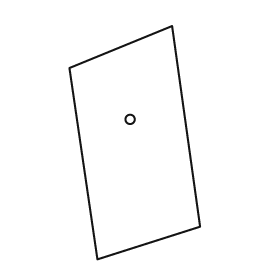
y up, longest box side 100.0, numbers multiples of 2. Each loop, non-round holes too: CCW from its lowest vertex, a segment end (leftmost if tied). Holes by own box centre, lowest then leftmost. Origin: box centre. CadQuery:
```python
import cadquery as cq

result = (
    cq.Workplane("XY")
    .moveTo(-16.0, -50.0)
    .lineTo(28.0, -36.0)
    .lineTo(16.0, 50.0)
    .lineTo(-28.0, 32.0)
    .close()
    .moveTo(-2.0, 10.0)
    .circle(2.0)
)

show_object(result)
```